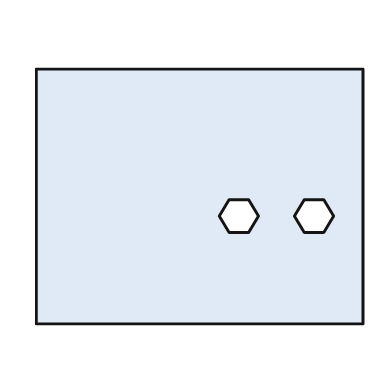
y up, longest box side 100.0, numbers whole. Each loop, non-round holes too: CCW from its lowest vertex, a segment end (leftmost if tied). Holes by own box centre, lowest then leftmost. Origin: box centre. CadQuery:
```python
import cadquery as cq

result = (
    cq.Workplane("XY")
    .moveTo(-50.0, -39.0)
    .lineTo(50.0, -39.0)
    .lineTo(50.0, 39.0)
    .lineTo(-50.0, 39.0)
    .close()
    .moveTo(9.0, -11.0)
    .lineTo(15.0, -11.0)
    .lineTo(18.0, -6.0)
    .lineTo(15.0, -1.0)
    .lineTo(9.0, -1.0)
    .lineTo(6.0, -6.0)
    .close()
    .moveTo(32.0, -11.0)
    .lineTo(38.0, -11.0)
    .lineTo(41.0, -6.0)
    .lineTo(38.0, -1.0)
    .lineTo(32.0, -1.0)
    .lineTo(29.0, -6.0)
    .close()
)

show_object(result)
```